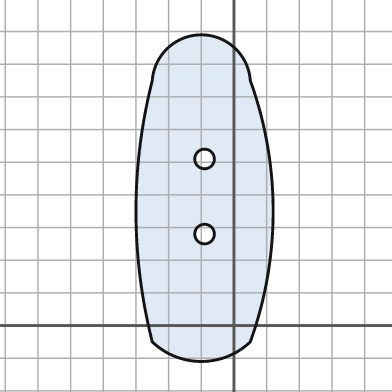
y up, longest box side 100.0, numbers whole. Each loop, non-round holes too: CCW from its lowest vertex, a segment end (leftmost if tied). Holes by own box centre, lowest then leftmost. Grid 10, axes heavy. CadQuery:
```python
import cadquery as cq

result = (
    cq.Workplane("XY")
    .moveTo(-25.0, -5.0)
    .threePointArc((-10.0, -11.0), (5.0, -5.0))
    .threePointArc((12.0, 35.0), (5.0, 75.0))
    .threePointArc((-10.0, 89.0), (-25.0, 75.0))
    .threePointArc((-30.0, 35.0), (-25.0, -5.0))
    .close()
    .moveTo(-9.0, 28.0)
    .circle(3.0)
    .moveTo(-9.0, 51.0)
    .circle(3.0)
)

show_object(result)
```